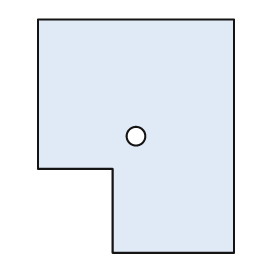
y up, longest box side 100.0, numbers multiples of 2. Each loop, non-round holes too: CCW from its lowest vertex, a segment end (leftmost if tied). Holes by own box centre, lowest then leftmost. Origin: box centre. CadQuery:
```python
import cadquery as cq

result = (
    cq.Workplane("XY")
    .moveTo(-10.0, -50.0)
    .lineTo(42.0, -50.0)
    .lineTo(42.0, 50.0)
    .lineTo(-42.0, 50.0)
    .lineTo(-42.0, -14.0)
    .lineTo(-10.0, -14.0)
    .close()
    .moveTo(0.0, 0.0)
    .circle(4.0)
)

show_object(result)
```